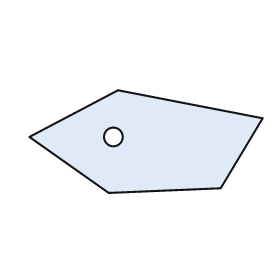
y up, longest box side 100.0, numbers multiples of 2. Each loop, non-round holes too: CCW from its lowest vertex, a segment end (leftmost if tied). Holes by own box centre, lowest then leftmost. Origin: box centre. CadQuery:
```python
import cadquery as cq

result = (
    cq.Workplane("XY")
    .moveTo(-16.0, -22.0)
    .lineTo(32.0, -20.0)
    .lineTo(50.0, 10.0)
    .lineTo(-12.0, 22.0)
    .lineTo(-50.0, 2.0)
    .close()
    .moveTo(-14.0, 2.0)
    .circle(4.0)
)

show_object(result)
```